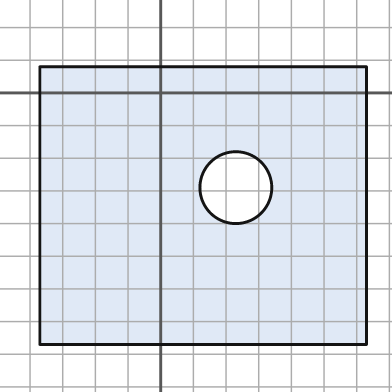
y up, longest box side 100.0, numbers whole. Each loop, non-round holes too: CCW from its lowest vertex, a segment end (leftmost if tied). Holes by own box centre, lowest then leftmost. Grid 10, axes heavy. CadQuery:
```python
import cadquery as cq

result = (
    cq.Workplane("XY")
    .moveTo(-37.0, -77.0)
    .lineTo(63.0, -77.0)
    .lineTo(63.0, 8.0)
    .lineTo(-37.0, 8.0)
    .close()
    .moveTo(23.0, -29.0)
    .circle(11.0)
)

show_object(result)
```